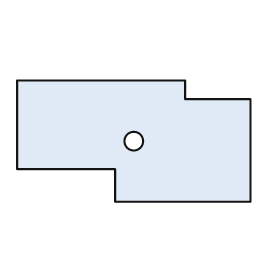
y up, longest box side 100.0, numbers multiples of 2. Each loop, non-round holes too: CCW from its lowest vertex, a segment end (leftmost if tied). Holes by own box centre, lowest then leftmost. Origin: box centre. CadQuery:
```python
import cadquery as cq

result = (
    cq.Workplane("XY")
    .moveTo(-8.0, -26.0)
    .lineTo(50.0, -26.0)
    .lineTo(50.0, 18.0)
    .lineTo(22.0, 18.0)
    .lineTo(22.0, 26.0)
    .lineTo(-50.0, 26.0)
    .lineTo(-50.0, -12.0)
    .lineTo(-8.0, -12.0)
    .close()
    .moveTo(0.0, 0.0)
    .circle(4.0)
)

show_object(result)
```